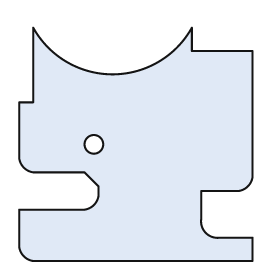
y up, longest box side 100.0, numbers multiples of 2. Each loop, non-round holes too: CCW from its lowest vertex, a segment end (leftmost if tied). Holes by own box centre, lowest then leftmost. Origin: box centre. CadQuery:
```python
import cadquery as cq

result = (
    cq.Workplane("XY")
    .moveTo(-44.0, -50.0)
    .lineTo(50.0, -50.0)
    .lineTo(50.0, -40.0)
    .lineTo(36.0, -40.0)
    .threePointArc((30.0, -38.0), (28.0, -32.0))
    .lineTo(28.0, -20.0)
    .lineTo(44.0, -20.0)
    .threePointArc((48.0, -18.0), (50.0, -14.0))
    .lineTo(50.0, 40.0)
    .lineTo(24.0, 40.0)
    .lineTo(24.0, 50.0)
    .threePointArc((-10.0, 30.0), (-44.0, 50.0))
    .lineTo(-44.0, 18.0)
    .lineTo(-50.0, 18.0)
    .lineTo(-50.0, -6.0)
    .threePointArc((-48.0, -10.0), (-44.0, -12.0))
    .lineTo(-22.0, -12.0)
    .lineTo(-16.0, -18.0)
    .lineTo(-16.0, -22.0)
    .threePointArc((-18.0, -26.0), (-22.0, -28.0))
    .lineTo(-50.0, -28.0)
    .lineTo(-50.0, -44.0)
    .threePointArc((-48.0, -48.0), (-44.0, -50.0))
    .close()
    .moveTo(-18.0, 0.0)
    .circle(4.0)
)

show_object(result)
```